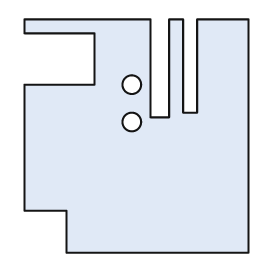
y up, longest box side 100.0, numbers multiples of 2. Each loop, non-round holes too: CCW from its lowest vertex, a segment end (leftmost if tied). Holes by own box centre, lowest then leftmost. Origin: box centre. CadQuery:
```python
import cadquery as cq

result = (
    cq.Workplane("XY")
    .moveTo(-30.0, -50.0)
    .lineTo(48.0, -50.0)
    .lineTo(48.0, 50.0)
    .lineTo(26.0, 50.0)
    .lineTo(26.0, 10.0)
    .lineTo(20.0, 10.0)
    .lineTo(20.0, 50.0)
    .lineTo(14.0, 50.0)
    .lineTo(14.0, 8.0)
    .lineTo(6.0, 8.0)
    .lineTo(6.0, 50.0)
    .lineTo(-48.0, 50.0)
    .lineTo(-48.0, 44.0)
    .lineTo(-18.0, 44.0)
    .lineTo(-18.0, 22.0)
    .lineTo(-48.0, 22.0)
    .lineTo(-48.0, -32.0)
    .lineTo(-30.0, -32.0)
    .close()
    .moveTo(-2.0, 6.0)
    .circle(4.0)
    .moveTo(-2.0, 22.0)
    .circle(4.0)
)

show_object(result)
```